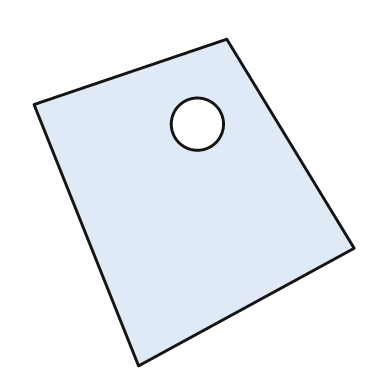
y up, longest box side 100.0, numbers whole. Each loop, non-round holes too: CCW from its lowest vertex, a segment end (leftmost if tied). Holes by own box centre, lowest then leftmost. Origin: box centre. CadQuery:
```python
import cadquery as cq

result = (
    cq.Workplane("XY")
    .moveTo(-17.0, -50.0)
    .lineTo(49.0, -14.0)
    .lineTo(10.0, 50.0)
    .lineTo(-49.0, 30.0)
    .close()
    .moveTo(1.0, 24.0)
    .circle(8.0)
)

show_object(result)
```